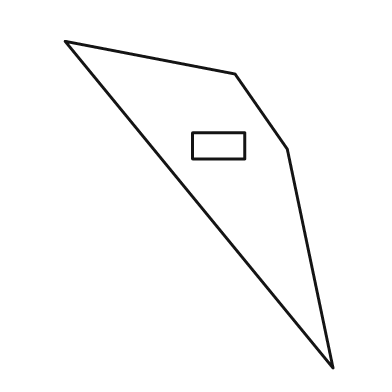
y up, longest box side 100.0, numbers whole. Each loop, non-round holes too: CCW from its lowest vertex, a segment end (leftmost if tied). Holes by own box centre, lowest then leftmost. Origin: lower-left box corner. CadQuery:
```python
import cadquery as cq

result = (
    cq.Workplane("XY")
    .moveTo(82.0, 0.0)
    .lineTo(68.0, 67.0)
    .lineTo(52.0, 90.0)
    .lineTo(0.0, 100.0)
    .close()
    .moveTo(39.0, 64.0)
    .lineTo(55.0, 64.0)
    .lineTo(55.0, 72.0)
    .lineTo(39.0, 72.0)
    .close()
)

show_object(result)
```